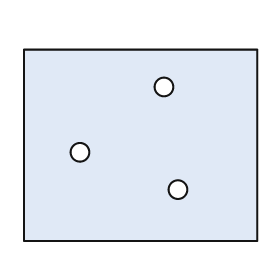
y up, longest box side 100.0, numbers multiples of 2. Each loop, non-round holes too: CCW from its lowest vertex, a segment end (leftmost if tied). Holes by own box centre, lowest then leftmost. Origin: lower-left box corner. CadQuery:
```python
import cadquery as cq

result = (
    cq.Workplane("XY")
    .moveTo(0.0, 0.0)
    .lineTo(100.0, 0.0)
    .lineTo(100.0, 82.0)
    .lineTo(0.0, 82.0)
    .close()
    .moveTo(66.0, 22.0)
    .circle(4.0)
    .moveTo(24.0, 38.0)
    .circle(4.0)
    .moveTo(60.0, 66.0)
    .circle(4.0)
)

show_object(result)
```